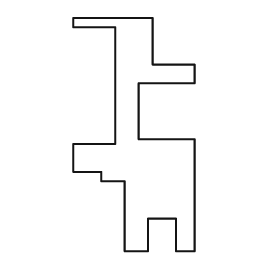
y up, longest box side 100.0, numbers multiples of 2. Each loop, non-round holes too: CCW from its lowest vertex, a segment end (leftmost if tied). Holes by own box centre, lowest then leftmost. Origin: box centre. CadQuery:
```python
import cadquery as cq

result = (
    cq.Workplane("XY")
    .moveTo(-4.0, -50.0)
    .lineTo(6.0, -50.0)
    .lineTo(6.0, -36.0)
    .lineTo(18.0, -36.0)
    .lineTo(18.0, -50.0)
    .lineTo(26.0, -50.0)
    .lineTo(26.0, -2.0)
    .lineTo(2.0, -2.0)
    .lineTo(2.0, 22.0)
    .lineTo(26.0, 22.0)
    .lineTo(26.0, 30.0)
    .lineTo(8.0, 30.0)
    .lineTo(8.0, 50.0)
    .lineTo(-26.0, 50.0)
    .lineTo(-26.0, 46.0)
    .lineTo(-8.0, 46.0)
    .lineTo(-8.0, -4.0)
    .lineTo(-26.0, -4.0)
    .lineTo(-26.0, -16.0)
    .lineTo(-14.0, -16.0)
    .lineTo(-14.0, -20.0)
    .lineTo(-4.0, -20.0)
    .close()
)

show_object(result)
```